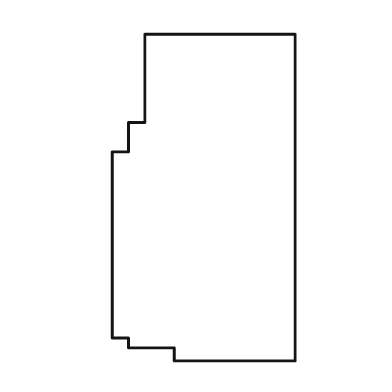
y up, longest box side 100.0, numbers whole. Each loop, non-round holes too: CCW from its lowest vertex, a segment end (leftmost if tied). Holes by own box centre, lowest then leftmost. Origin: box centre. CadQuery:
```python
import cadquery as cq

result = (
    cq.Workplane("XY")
    .moveTo(-9.0, -50.0)
    .lineTo(28.0, -50.0)
    .lineTo(28.0, 50.0)
    .lineTo(-18.0, 50.0)
    .lineTo(-18.0, 23.0)
    .lineTo(-23.0, 23.0)
    .lineTo(-23.0, 14.0)
    .lineTo(-28.0, 14.0)
    .lineTo(-28.0, -43.0)
    .lineTo(-23.0, -43.0)
    .lineTo(-23.0, -46.0)
    .lineTo(-9.0, -46.0)
    .close()
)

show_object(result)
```